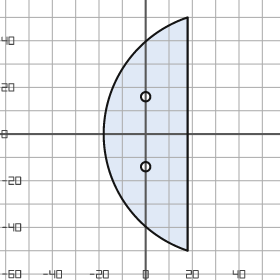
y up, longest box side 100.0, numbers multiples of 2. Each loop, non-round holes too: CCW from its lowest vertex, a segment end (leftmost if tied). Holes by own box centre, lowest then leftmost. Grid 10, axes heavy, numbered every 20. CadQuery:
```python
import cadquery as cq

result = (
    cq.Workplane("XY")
    .moveTo(18.0, -50.0)
    .lineTo(18.0, 50.0)
    .threePointArc((-18.0, 0.0), (18.0, -50.0))
    .close()
    .moveTo(0.0, -14.0)
    .circle(2.0)
    .moveTo(0.0, 16.0)
    .circle(2.0)
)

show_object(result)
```